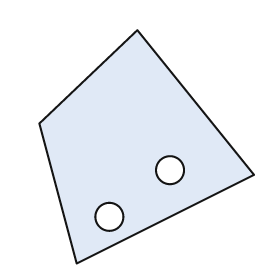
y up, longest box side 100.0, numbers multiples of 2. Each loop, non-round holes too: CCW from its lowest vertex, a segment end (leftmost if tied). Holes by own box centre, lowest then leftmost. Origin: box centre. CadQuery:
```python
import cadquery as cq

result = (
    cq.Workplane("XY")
    .moveTo(-30.0, -50.0)
    .lineTo(46.0, -12.0)
    .lineTo(-4.0, 50.0)
    .lineTo(-46.0, 10.0)
    .close()
    .moveTo(-16.0, -30.0)
    .circle(6.0)
    .moveTo(10.0, -10.0)
    .circle(6.0)
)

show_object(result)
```